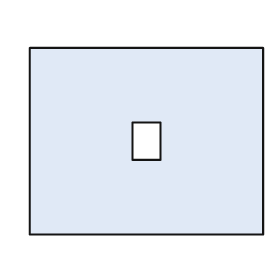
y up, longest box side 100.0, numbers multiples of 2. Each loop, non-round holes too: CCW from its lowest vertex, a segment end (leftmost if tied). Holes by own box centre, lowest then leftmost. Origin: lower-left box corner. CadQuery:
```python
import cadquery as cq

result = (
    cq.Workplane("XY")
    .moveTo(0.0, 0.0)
    .lineTo(100.0, 0.0)
    .lineTo(100.0, 80.0)
    .lineTo(0.0, 80.0)
    .close()
    .moveTo(44.0, 32.0)
    .lineTo(56.0, 32.0)
    .lineTo(56.0, 48.0)
    .lineTo(44.0, 48.0)
    .close()
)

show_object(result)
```